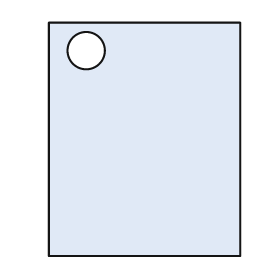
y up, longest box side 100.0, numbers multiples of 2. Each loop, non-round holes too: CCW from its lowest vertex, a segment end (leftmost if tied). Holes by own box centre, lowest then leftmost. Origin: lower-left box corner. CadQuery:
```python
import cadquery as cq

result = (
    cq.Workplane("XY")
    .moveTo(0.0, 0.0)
    .lineTo(82.0, 0.0)
    .lineTo(82.0, 100.0)
    .lineTo(0.0, 100.0)
    .close()
    .moveTo(16.0, 88.0)
    .circle(8.0)
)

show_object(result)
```